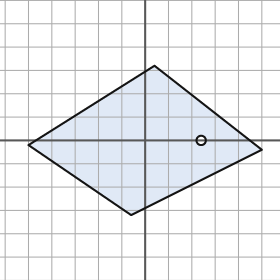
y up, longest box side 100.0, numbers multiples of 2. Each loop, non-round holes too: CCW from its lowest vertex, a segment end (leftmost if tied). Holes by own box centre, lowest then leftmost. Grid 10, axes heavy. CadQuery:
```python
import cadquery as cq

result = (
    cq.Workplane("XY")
    .moveTo(-6.0, -32.0)
    .lineTo(50.0, -4.0)
    .lineTo(4.0, 32.0)
    .lineTo(-50.0, -2.0)
    .close()
    .moveTo(24.0, 0.0)
    .circle(2.0)
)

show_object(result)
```